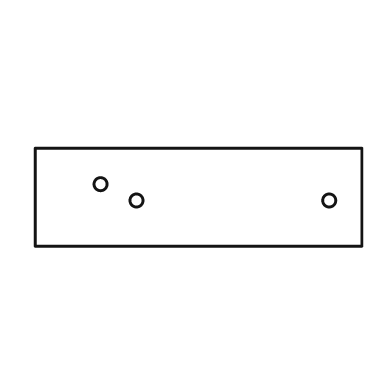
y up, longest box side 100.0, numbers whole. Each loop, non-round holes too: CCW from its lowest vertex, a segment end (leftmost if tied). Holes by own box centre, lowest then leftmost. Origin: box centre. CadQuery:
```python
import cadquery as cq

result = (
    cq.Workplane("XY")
    .moveTo(-50.0, -15.0)
    .lineTo(50.0, -15.0)
    .lineTo(50.0, 15.0)
    .lineTo(-50.0, 15.0)
    .close()
    .moveTo(-19.0, -1.0)
    .circle(2.0)
    .moveTo(40.0, -1.0)
    .circle(2.0)
    .moveTo(-30.0, 4.0)
    .circle(2.0)
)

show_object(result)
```